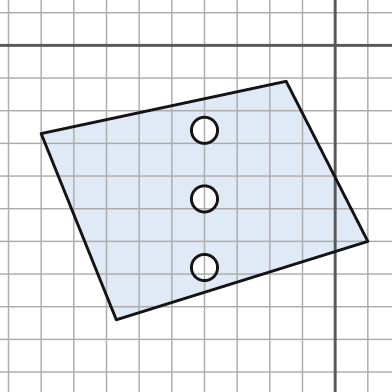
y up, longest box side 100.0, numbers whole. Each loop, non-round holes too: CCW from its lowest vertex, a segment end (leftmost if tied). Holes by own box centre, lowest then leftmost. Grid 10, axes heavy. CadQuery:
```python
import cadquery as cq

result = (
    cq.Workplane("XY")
    .moveTo(-67.0, -84.0)
    .lineTo(10.0, -60.0)
    .lineTo(-15.0, -11.0)
    .lineTo(-90.0, -27.0)
    .close()
    .moveTo(-40.0, -68.0)
    .circle(4.0)
    .moveTo(-40.0, -47.0)
    .circle(4.0)
    .moveTo(-40.0, -26.0)
    .circle(4.0)
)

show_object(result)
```